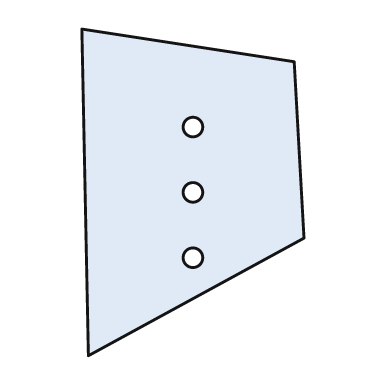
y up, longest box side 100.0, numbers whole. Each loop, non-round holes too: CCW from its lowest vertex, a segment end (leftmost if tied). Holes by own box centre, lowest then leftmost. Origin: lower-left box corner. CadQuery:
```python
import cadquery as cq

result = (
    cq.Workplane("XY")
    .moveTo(2.0, 0.0)
    .lineTo(68.0, 36.0)
    .lineTo(65.0, 90.0)
    .lineTo(0.0, 100.0)
    .close()
    .moveTo(34.0, 30.0)
    .circle(3.0)
    .moveTo(34.0, 50.0)
    .circle(3.0)
    .moveTo(34.0, 70.0)
    .circle(3.0)
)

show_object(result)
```